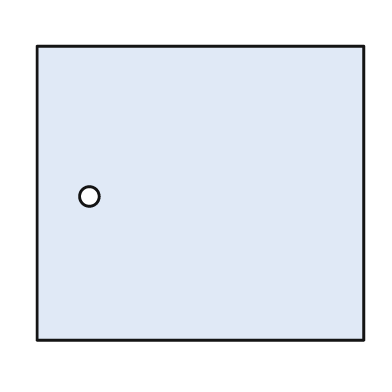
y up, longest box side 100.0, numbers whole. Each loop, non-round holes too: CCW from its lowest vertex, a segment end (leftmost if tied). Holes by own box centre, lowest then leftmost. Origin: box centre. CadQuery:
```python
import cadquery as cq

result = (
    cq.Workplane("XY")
    .moveTo(-50.0, -45.0)
    .lineTo(50.0, -45.0)
    .lineTo(50.0, 45.0)
    .lineTo(-50.0, 45.0)
    .close()
    .moveTo(-34.0, -1.0)
    .circle(3.0)
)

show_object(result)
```